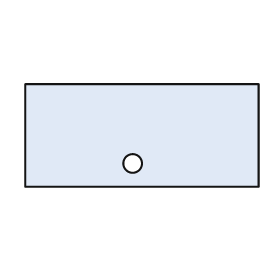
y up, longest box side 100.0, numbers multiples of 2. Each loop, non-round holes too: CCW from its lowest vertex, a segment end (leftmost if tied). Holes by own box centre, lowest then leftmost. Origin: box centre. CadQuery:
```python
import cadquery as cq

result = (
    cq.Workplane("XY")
    .moveTo(-50.0, -22.0)
    .lineTo(50.0, -22.0)
    .lineTo(50.0, 22.0)
    .lineTo(-50.0, 22.0)
    .close()
    .moveTo(-4.0, -12.0)
    .circle(4.0)
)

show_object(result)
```